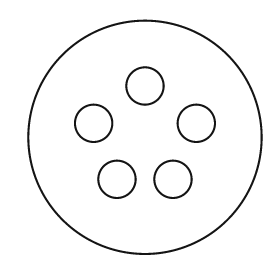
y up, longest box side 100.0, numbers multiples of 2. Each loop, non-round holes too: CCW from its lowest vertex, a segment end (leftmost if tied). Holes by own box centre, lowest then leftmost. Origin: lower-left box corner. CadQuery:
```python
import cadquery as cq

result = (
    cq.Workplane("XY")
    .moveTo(50.0, 50.0)
    .circle(50.0)
    .moveTo(38.0, 32.0)
    .circle(8.0)
    .moveTo(62.0, 32.0)
    .circle(8.0)
    .moveTo(28.0, 56.0)
    .circle(8.0)
    .moveTo(72.0, 56.0)
    .circle(8.0)
    .moveTo(50.0, 72.0)
    .circle(8.0)
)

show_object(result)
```